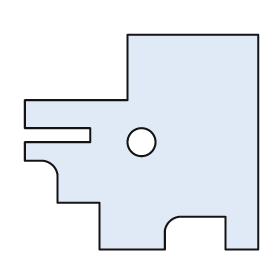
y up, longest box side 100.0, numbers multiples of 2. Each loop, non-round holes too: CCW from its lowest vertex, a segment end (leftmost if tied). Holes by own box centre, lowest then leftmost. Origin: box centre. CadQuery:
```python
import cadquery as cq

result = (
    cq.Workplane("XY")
    .moveTo(-18.0, -46.0)
    .lineTo(10.0, -46.0)
    .lineTo(10.0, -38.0)
    .threePointArc((12.0, -34.0), (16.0, -32.0))
    .lineTo(36.0, -32.0)
    .lineTo(36.0, -46.0)
    .lineTo(50.0, -46.0)
    .lineTo(50.0, 46.0)
    .lineTo(-6.0, 46.0)
    .lineTo(-6.0, 18.0)
    .lineTo(-50.0, 18.0)
    .lineTo(-50.0, 6.0)
    .lineTo(-22.0, 6.0)
    .lineTo(-22.0, 0.0)
    .lineTo(-50.0, 0.0)
    .lineTo(-50.0, -8.0)
    .lineTo(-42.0, -8.0)
    .threePointArc((-38.0, -10.0), (-36.0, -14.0))
    .lineTo(-36.0, -26.0)
    .lineTo(-18.0, -26.0)
    .close()
    .moveTo(0.0, 0.0)
    .circle(6.0)
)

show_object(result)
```